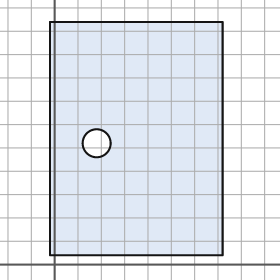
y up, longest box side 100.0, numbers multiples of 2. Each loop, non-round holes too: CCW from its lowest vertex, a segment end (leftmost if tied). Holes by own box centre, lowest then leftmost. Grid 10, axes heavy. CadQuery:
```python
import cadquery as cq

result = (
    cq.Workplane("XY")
    .moveTo(-2.0, 4.0)
    .lineTo(72.0, 4.0)
    .lineTo(72.0, 104.0)
    .lineTo(-2.0, 104.0)
    .close()
    .moveTo(18.0, 52.0)
    .circle(6.0)
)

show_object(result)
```